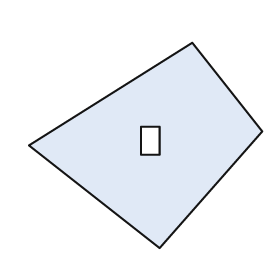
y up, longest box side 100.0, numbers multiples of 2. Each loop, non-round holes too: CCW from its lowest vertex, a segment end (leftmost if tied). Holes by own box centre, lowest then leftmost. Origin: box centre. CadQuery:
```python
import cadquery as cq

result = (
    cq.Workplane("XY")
    .moveTo(6.0, -44.0)
    .lineTo(50.0, 6.0)
    .lineTo(20.0, 44.0)
    .lineTo(-50.0, 0.0)
    .close()
    .moveTo(-2.0, -4.0)
    .lineTo(6.0, -4.0)
    .lineTo(6.0, 8.0)
    .lineTo(-2.0, 8.0)
    .close()
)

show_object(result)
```